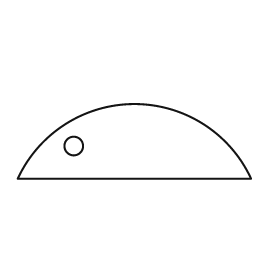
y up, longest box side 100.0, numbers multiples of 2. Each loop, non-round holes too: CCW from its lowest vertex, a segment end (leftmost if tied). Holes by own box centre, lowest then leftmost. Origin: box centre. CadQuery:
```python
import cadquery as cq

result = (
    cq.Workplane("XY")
    .moveTo(-50.0, -16.0)
    .lineTo(50.0, -16.0)
    .threePointArc((0.0, 16.0), (-50.0, -16.0))
    .close()
    .moveTo(-26.0, -2.0)
    .circle(4.0)
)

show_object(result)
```